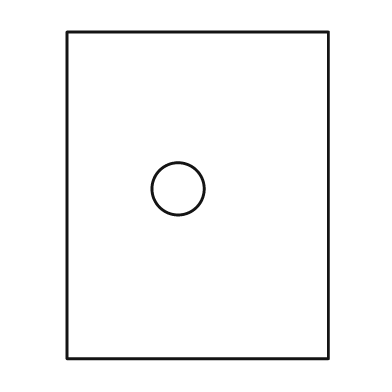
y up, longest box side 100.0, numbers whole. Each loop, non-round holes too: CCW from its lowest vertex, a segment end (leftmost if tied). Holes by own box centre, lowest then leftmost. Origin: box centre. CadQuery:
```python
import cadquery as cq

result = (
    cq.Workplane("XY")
    .moveTo(-40.0, -50.0)
    .lineTo(40.0, -50.0)
    .lineTo(40.0, 50.0)
    .lineTo(-40.0, 50.0)
    .close()
    .moveTo(-6.0, 2.0)
    .circle(8.0)
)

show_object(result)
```